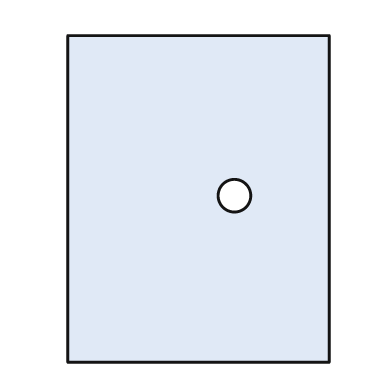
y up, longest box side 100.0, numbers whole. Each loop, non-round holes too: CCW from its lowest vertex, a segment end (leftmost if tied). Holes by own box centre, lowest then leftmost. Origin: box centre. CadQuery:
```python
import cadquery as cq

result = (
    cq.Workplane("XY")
    .moveTo(-40.0, -50.0)
    .lineTo(40.0, -50.0)
    .lineTo(40.0, 50.0)
    .lineTo(-40.0, 50.0)
    .close()
    .moveTo(11.0, 1.0)
    .circle(5.0)
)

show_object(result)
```